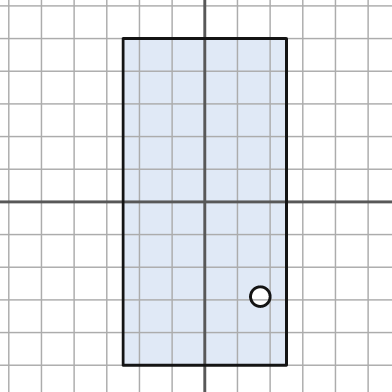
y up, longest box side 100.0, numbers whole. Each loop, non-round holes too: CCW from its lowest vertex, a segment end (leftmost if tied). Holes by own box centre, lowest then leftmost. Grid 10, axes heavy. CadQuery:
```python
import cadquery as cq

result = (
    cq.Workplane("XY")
    .moveTo(-25.0, -50.0)
    .lineTo(25.0, -50.0)
    .lineTo(25.0, 50.0)
    .lineTo(-25.0, 50.0)
    .close()
    .moveTo(17.0, -29.0)
    .circle(3.0)
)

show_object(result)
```